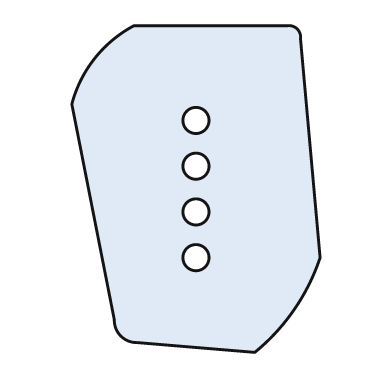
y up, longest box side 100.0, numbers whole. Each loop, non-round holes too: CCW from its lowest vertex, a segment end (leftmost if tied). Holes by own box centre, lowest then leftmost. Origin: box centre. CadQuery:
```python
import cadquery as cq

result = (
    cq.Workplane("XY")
    .moveTo(18.0, -50.0)
    .threePointArc((30.0, -37.0), (38.0, -21.0))
    .lineTo(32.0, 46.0)
    .threePointArc((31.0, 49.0), (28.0, 50.0))
    .lineTo(-19.0, 50.0)
    .threePointArc((-31.0, 40.0), (-38.0, 26.0))
    .lineTo(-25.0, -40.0)
    .threePointArc((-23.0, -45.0), (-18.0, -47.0))
    .close()
    .moveTo(0.0, -21.0)
    .circle(4.0)
    .moveTo(0.0, -7.0)
    .circle(4.0)
    .moveTo(0.0, 7.0)
    .circle(4.0)
    .moveTo(0.0, 21.0)
    .circle(4.0)
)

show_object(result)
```